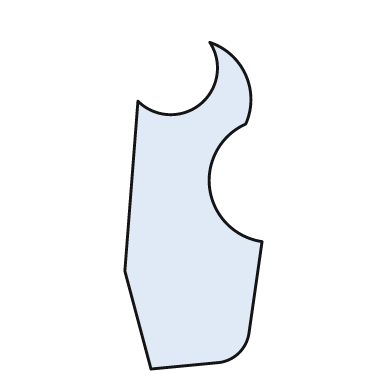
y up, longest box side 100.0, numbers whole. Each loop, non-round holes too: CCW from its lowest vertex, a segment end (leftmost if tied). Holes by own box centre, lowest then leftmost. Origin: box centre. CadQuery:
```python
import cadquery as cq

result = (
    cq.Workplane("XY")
    .moveTo(-13.0, -50.0)
    .lineTo(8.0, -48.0)
    .threePointArc((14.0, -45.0), (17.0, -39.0))
    .lineTo(21.0, -11.0)
    .threePointArc((5.0, 5.0), (16.0, 25.0))
    .threePointArc((16.0, 40.0), (5.0, 50.0))
    .threePointArc((2.0, 31.0), (-17.0, 32.0))
    .lineTo(-21.0, -20.0)
    .close()
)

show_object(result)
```